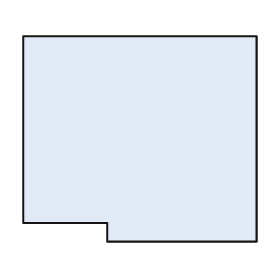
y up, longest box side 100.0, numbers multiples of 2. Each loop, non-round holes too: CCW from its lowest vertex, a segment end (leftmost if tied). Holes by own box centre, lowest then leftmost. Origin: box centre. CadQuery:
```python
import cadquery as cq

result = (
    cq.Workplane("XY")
    .moveTo(-14.0, -44.0)
    .lineTo(50.0, -44.0)
    .lineTo(50.0, 44.0)
    .lineTo(-50.0, 44.0)
    .lineTo(-50.0, -36.0)
    .lineTo(-14.0, -36.0)
    .close()
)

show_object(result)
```